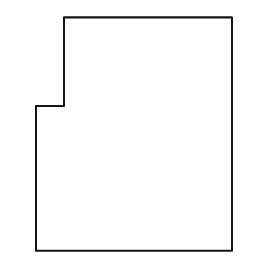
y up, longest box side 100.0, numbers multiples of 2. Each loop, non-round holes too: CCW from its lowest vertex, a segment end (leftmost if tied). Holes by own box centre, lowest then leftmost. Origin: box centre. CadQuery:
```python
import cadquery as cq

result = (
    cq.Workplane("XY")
    .moveTo(-42.0, -50.0)
    .lineTo(42.0, -50.0)
    .lineTo(42.0, 50.0)
    .lineTo(-30.0, 50.0)
    .lineTo(-30.0, 12.0)
    .lineTo(-42.0, 12.0)
    .close()
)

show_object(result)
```